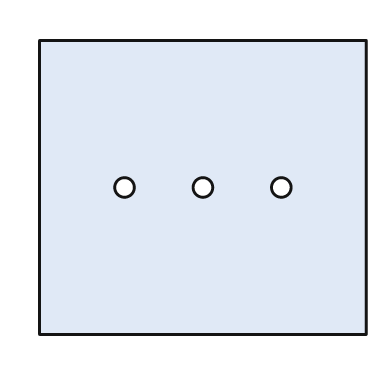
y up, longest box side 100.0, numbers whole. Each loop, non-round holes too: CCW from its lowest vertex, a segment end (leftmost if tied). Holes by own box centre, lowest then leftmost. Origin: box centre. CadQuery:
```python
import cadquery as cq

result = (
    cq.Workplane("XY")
    .moveTo(-50.0, -45.0)
    .lineTo(50.0, -45.0)
    .lineTo(50.0, 45.0)
    .lineTo(-50.0, 45.0)
    .close()
    .moveTo(-24.0, 0.0)
    .circle(3.0)
    .moveTo(0.0, 0.0)
    .circle(3.0)
    .moveTo(24.0, 0.0)
    .circle(3.0)
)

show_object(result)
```